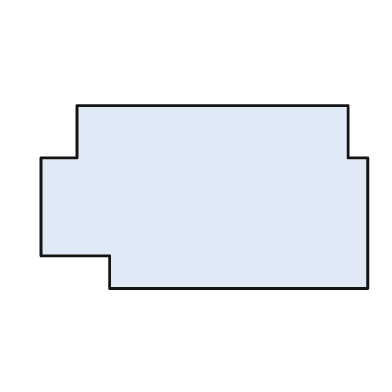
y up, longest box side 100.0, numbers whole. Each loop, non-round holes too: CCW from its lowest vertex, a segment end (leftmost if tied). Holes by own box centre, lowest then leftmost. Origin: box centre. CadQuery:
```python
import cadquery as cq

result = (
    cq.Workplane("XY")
    .moveTo(-29.0, -28.0)
    .lineTo(50.0, -28.0)
    .lineTo(50.0, 12.0)
    .lineTo(44.0, 12.0)
    .lineTo(44.0, 28.0)
    .lineTo(-39.0, 28.0)
    .lineTo(-39.0, 12.0)
    .lineTo(-50.0, 12.0)
    .lineTo(-50.0, -18.0)
    .lineTo(-29.0, -18.0)
    .close()
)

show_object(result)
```